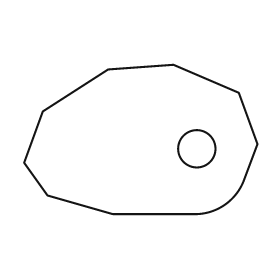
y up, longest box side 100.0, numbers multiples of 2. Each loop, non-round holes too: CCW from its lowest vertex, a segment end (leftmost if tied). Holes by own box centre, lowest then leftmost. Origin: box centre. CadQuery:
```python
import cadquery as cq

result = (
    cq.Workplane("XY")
    .moveTo(-12.0, -32.0)
    .lineTo(24.0, -32.0)
    .threePointArc((36.0, -28.0), (44.0, -18.0))
    .lineTo(50.0, -2.0)
    .lineTo(42.0, 20.0)
    .lineTo(14.0, 32.0)
    .lineTo(-14.0, 30.0)
    .lineTo(-42.0, 12.0)
    .lineTo(-50.0, -10.0)
    .lineTo(-40.0, -24.0)
    .close()
    .moveTo(24.0, -4.0)
    .circle(8.0)
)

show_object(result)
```